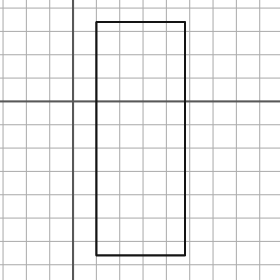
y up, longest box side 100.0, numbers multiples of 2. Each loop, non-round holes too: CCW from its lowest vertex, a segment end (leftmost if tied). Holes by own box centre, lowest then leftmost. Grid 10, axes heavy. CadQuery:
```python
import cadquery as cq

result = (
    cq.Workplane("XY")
    .moveTo(10.0, -66.0)
    .lineTo(48.0, -66.0)
    .lineTo(48.0, 34.0)
    .lineTo(10.0, 34.0)
    .close()
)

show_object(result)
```